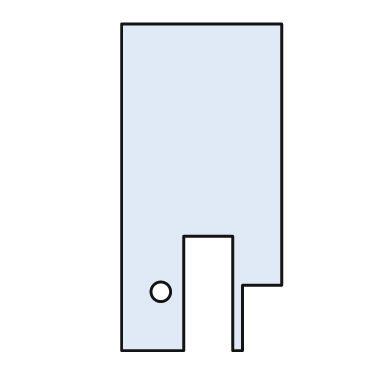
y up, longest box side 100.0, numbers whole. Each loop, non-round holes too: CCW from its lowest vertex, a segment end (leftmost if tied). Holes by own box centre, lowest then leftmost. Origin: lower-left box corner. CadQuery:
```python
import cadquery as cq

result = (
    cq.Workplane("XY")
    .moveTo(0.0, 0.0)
    .lineTo(19.0, 0.0)
    .lineTo(19.0, 35.0)
    .lineTo(34.0, 35.0)
    .lineTo(34.0, 0.0)
    .lineTo(37.0, 0.0)
    .lineTo(37.0, 20.0)
    .lineTo(49.0, 20.0)
    .lineTo(49.0, 100.0)
    .lineTo(0.0, 100.0)
    .close()
    .moveTo(12.0, 18.0)
    .circle(3.0)
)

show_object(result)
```